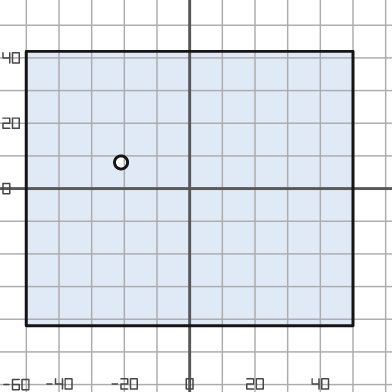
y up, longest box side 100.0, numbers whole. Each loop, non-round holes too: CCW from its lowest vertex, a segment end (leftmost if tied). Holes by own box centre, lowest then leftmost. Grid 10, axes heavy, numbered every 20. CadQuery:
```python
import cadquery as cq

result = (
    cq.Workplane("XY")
    .moveTo(-50.0, -42.0)
    .lineTo(50.0, -42.0)
    .lineTo(50.0, 42.0)
    .lineTo(-50.0, 42.0)
    .close()
    .moveTo(-21.0, 8.0)
    .circle(2.0)
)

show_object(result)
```